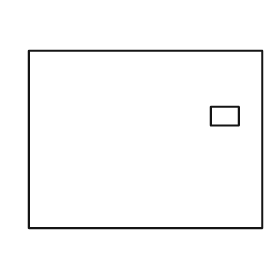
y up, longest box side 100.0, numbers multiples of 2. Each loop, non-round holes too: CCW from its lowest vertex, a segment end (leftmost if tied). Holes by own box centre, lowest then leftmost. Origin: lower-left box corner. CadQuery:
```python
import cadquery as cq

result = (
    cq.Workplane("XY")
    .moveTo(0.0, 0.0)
    .lineTo(100.0, 0.0)
    .lineTo(100.0, 76.0)
    .lineTo(0.0, 76.0)
    .close()
    .moveTo(78.0, 44.0)
    .lineTo(90.0, 44.0)
    .lineTo(90.0, 52.0)
    .lineTo(78.0, 52.0)
    .close()
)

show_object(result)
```